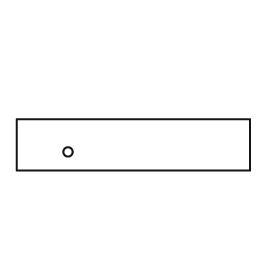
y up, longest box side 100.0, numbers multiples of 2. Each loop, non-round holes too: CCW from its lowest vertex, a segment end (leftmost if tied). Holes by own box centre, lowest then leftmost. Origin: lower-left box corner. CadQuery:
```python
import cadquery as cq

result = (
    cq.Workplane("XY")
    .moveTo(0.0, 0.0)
    .lineTo(100.0, 0.0)
    .lineTo(100.0, 22.0)
    .lineTo(0.0, 22.0)
    .close()
    .moveTo(22.0, 8.0)
    .circle(2.0)
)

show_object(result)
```